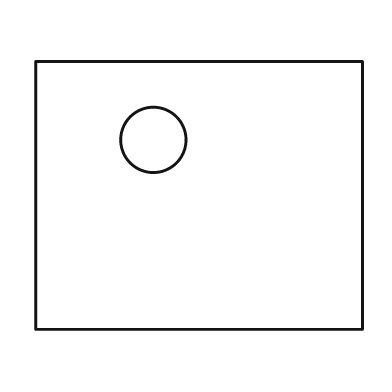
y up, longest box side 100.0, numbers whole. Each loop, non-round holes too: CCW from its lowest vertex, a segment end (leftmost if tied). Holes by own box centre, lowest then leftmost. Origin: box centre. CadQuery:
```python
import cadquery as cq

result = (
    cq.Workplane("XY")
    .moveTo(-50.0, -41.0)
    .lineTo(50.0, -41.0)
    .lineTo(50.0, 41.0)
    .lineTo(-50.0, 41.0)
    .close()
    .moveTo(-14.0, 17.0)
    .circle(10.0)
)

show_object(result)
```